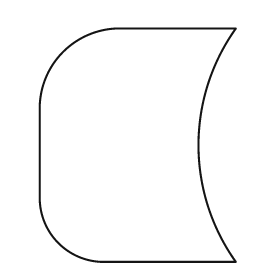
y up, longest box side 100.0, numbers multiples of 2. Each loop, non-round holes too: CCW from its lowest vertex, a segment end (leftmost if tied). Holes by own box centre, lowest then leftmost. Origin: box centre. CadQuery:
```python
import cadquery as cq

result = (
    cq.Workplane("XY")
    .moveTo(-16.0, -50.0)
    .lineTo(42.0, -50.0)
    .threePointArc((26.0, 0.0), (42.0, 50.0))
    .lineTo(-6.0, 50.0)
    .threePointArc((-32.0, 40.0), (-42.0, 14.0))
    .lineTo(-42.0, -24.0)
    .threePointArc((-34.0, -42.0), (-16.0, -50.0))
    .close()
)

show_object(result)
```